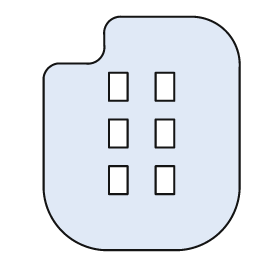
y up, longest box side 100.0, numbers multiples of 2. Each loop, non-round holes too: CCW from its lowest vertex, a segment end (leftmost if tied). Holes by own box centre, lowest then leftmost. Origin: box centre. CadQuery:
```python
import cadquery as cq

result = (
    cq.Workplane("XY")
    .moveTo(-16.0, -50.0)
    .lineTo(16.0, -50.0)
    .threePointArc((34.0, -42.0), (42.0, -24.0))
    .lineTo(42.0, 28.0)
    .threePointArc((36.0, 44.0), (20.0, 50.0))
    .lineTo(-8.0, 50.0)
    .threePointArc((-14.0, 48.0), (-16.0, 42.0))
    .lineTo(-16.0, 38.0)
    .threePointArc((-18.0, 32.0), (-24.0, 30.0))
    .lineTo(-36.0, 30.0)
    .threePointArc((-40.0, 28.0), (-42.0, 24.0))
    .lineTo(-42.0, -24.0)
    .threePointArc((-34.0, -42.0), (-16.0, -50.0))
    .close()
    .moveTo(-14.0, -26.0)
    .lineTo(-6.0, -26.0)
    .lineTo(-6.0, -14.0)
    .lineTo(-14.0, -14.0)
    .close()
    .moveTo(6.0, -26.0)
    .lineTo(14.0, -26.0)
    .lineTo(14.0, -14.0)
    .lineTo(6.0, -14.0)
    .close()
    .moveTo(-14.0, -6.0)
    .lineTo(-6.0, -6.0)
    .lineTo(-6.0, 6.0)
    .lineTo(-14.0, 6.0)
    .close()
    .moveTo(6.0, -6.0)
    .lineTo(14.0, -6.0)
    .lineTo(14.0, 6.0)
    .lineTo(6.0, 6.0)
    .close()
    .moveTo(-14.0, 14.0)
    .lineTo(-6.0, 14.0)
    .lineTo(-6.0, 26.0)
    .lineTo(-14.0, 26.0)
    .close()
    .moveTo(6.0, 14.0)
    .lineTo(14.0, 14.0)
    .lineTo(14.0, 26.0)
    .lineTo(6.0, 26.0)
    .close()
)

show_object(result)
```